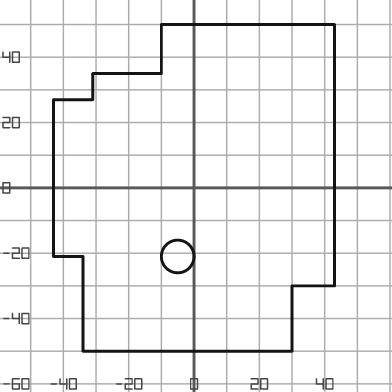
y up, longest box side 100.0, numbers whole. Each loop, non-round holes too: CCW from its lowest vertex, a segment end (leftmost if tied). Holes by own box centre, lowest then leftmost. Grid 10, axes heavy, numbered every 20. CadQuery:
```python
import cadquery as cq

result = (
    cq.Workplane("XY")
    .moveTo(-34.0, -50.0)
    .lineTo(30.0, -50.0)
    .lineTo(30.0, -30.0)
    .lineTo(43.0, -30.0)
    .lineTo(43.0, 50.0)
    .lineTo(-10.0, 50.0)
    .lineTo(-10.0, 35.0)
    .lineTo(-31.0, 35.0)
    .lineTo(-31.0, 27.0)
    .lineTo(-43.0, 27.0)
    .lineTo(-43.0, -21.0)
    .lineTo(-34.0, -21.0)
    .close()
    .moveTo(-5.0, -21.0)
    .circle(5.0)
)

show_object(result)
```